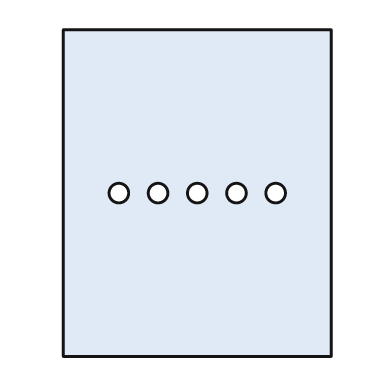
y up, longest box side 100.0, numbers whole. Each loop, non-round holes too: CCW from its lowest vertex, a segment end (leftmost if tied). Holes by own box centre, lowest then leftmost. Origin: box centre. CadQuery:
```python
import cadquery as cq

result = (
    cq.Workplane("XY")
    .moveTo(-41.0, -50.0)
    .lineTo(41.0, -50.0)
    .lineTo(41.0, 50.0)
    .lineTo(-41.0, 50.0)
    .close()
    .moveTo(-24.0, 0.0)
    .circle(3.0)
    .moveTo(-12.0, 0.0)
    .circle(3.0)
    .moveTo(0.0, 0.0)
    .circle(3.0)
    .moveTo(12.0, 0.0)
    .circle(3.0)
    .moveTo(24.0, 0.0)
    .circle(3.0)
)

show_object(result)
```